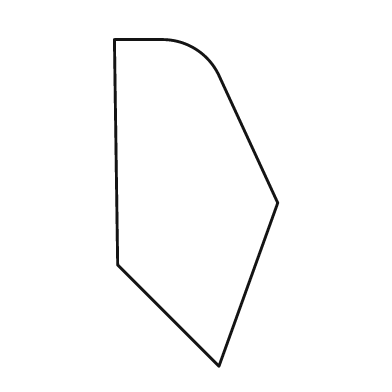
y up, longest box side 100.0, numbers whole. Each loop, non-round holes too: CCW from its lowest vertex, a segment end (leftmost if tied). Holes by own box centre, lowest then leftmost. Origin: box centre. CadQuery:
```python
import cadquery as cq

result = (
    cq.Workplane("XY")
    .moveTo(7.0, -50.0)
    .lineTo(25.0, 0.0)
    .lineTo(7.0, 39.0)
    .threePointArc((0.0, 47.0), (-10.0, 50.0))
    .lineTo(-25.0, 50.0)
    .lineTo(-24.0, -19.0)
    .close()
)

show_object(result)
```